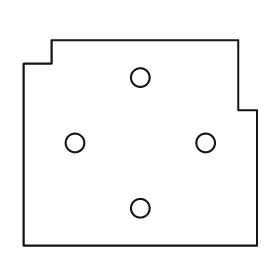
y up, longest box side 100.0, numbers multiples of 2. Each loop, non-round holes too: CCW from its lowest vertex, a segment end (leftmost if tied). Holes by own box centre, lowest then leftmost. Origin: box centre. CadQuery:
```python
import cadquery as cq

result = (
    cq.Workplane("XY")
    .moveTo(-50.0, -44.0)
    .lineTo(50.0, -44.0)
    .lineTo(50.0, 14.0)
    .lineTo(42.0, 14.0)
    .lineTo(42.0, 44.0)
    .lineTo(-38.0, 44.0)
    .lineTo(-38.0, 34.0)
    .lineTo(-50.0, 34.0)
    .close()
    .moveTo(0.0, -28.0)
    .circle(4.0)
    .moveTo(-28.0, 0.0)
    .circle(4.0)
    .moveTo(28.0, 0.0)
    .circle(4.0)
    .moveTo(0.0, 28.0)
    .circle(4.0)
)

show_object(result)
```